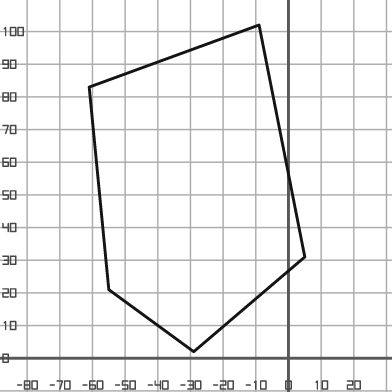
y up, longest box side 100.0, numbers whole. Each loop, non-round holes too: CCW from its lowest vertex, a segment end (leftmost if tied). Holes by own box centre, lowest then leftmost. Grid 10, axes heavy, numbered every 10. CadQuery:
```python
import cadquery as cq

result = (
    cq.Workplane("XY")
    .moveTo(-29.0, 2.0)
    .lineTo(5.0, 31.0)
    .lineTo(-9.0, 102.0)
    .lineTo(-61.0, 83.0)
    .lineTo(-55.0, 21.0)
    .close()
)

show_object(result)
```